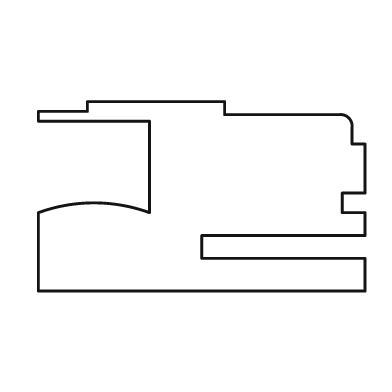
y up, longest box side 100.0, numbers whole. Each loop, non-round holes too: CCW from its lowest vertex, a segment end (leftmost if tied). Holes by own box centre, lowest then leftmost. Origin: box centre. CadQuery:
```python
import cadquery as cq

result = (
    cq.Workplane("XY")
    .moveTo(-50.0, -29.0)
    .lineTo(50.0, -29.0)
    .lineTo(50.0, -19.0)
    .lineTo(0.0, -19.0)
    .lineTo(0.0, -12.0)
    .lineTo(50.0, -12.0)
    .lineTo(50.0, -5.0)
    .lineTo(43.0, -5.0)
    .lineTo(43.0, 1.0)
    .lineTo(50.0, 1.0)
    .lineTo(50.0, 16.0)
    .lineTo(46.0, 16.0)
    .lineTo(46.0, 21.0)
    .threePointArc((45.0, 24.0), (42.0, 25.0))
    .lineTo(7.0, 25.0)
    .lineTo(7.0, 29.0)
    .lineTo(-35.0, 29.0)
    .lineTo(-35.0, 26.0)
    .lineTo(-50.0, 26.0)
    .lineTo(-50.0, 23.0)
    .lineTo(-16.0, 23.0)
    .lineTo(-16.0, -5.0)
    .threePointArc((-33.0, -2.0), (-50.0, -5.0))
    .close()
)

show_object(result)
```